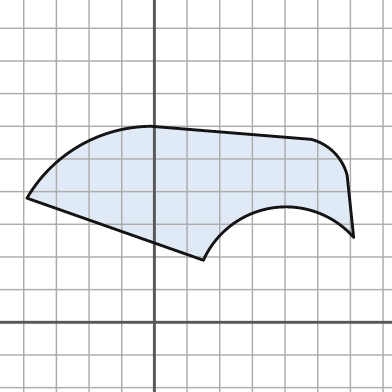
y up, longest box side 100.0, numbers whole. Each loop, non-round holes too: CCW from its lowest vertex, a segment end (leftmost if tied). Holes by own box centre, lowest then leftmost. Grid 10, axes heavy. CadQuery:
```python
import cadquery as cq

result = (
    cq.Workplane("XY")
    .moveTo(15.0, 19.0)
    .threePointArc((36.0, 35.0), (61.0, 26.0))
    .lineTo(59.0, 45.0)
    .threePointArc((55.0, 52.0), (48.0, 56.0))
    .lineTo(-1.0, 60.0)
    .threePointArc((-23.0, 54.0), (-39.0, 38.0))
    .close()
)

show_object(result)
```